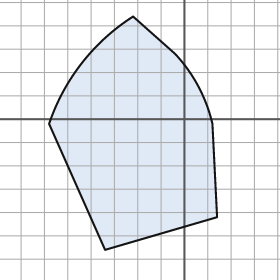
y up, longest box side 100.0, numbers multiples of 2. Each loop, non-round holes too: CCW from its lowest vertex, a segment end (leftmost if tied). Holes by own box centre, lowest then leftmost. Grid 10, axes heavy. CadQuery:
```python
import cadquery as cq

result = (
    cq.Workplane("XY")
    .moveTo(-34.0, -56.0)
    .lineTo(14.0, -42.0)
    .lineTo(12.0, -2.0)
    .threePointArc((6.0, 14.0), (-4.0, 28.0))
    .lineTo(-22.0, 44.0)
    .threePointArc((-44.0, 24.0), (-58.0, -2.0))
    .close()
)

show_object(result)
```